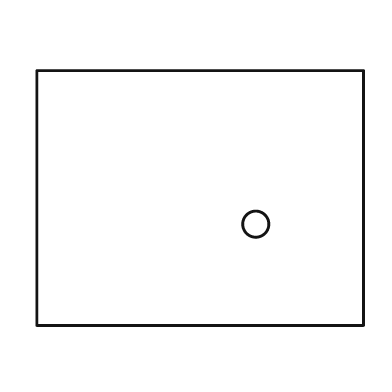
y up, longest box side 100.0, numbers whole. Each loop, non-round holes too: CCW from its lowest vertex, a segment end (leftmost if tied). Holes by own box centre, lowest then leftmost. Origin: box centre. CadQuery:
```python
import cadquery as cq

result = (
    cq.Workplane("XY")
    .moveTo(-50.0, -39.0)
    .lineTo(50.0, -39.0)
    .lineTo(50.0, 39.0)
    .lineTo(-50.0, 39.0)
    .close()
    .moveTo(17.0, -8.0)
    .circle(4.0)
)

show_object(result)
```